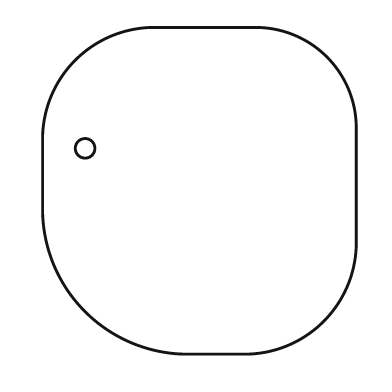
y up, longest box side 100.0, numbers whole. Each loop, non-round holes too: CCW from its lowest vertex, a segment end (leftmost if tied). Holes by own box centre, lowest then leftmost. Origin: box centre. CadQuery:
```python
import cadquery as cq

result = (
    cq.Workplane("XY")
    .moveTo(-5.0, -50.0)
    .lineTo(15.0, -50.0)
    .threePointArc((38.0, -40.0), (48.0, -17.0))
    .lineTo(48.0, 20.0)
    .threePointArc((39.0, 41.0), (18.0, 50.0))
    .lineTo(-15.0, 50.0)
    .threePointArc((-38.0, 40.0), (-48.0, 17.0))
    .lineTo(-48.0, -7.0)
    .threePointArc((-35.0, -37.0), (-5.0, -50.0))
    .close()
    .moveTo(-35.0, 13.0)
    .circle(3.0)
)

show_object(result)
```